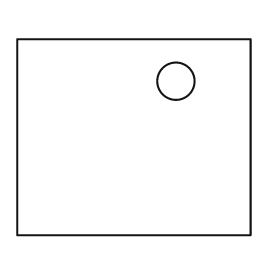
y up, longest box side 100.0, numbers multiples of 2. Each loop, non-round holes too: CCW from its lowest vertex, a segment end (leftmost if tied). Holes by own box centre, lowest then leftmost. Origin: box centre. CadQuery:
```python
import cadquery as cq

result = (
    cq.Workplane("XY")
    .moveTo(-50.0, -42.0)
    .lineTo(50.0, -42.0)
    .lineTo(50.0, 42.0)
    .lineTo(-50.0, 42.0)
    .close()
    .moveTo(18.0, 24.0)
    .circle(8.0)
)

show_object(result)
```